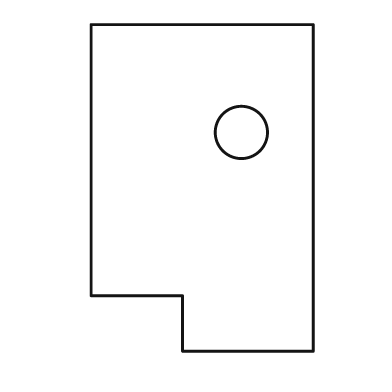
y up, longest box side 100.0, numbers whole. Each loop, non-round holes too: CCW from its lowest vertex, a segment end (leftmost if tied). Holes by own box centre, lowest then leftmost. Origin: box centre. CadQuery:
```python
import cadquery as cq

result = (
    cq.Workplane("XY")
    .moveTo(-6.0, -50.0)
    .lineTo(34.0, -50.0)
    .lineTo(34.0, 50.0)
    .lineTo(-34.0, 50.0)
    .lineTo(-34.0, -33.0)
    .lineTo(-6.0, -33.0)
    .close()
    .moveTo(12.0, 17.0)
    .circle(8.0)
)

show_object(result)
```